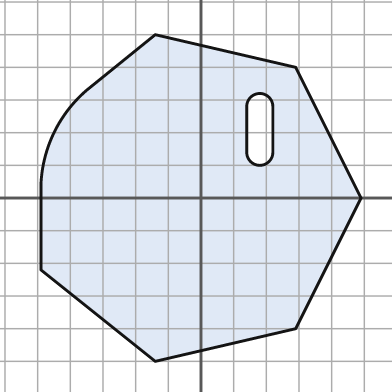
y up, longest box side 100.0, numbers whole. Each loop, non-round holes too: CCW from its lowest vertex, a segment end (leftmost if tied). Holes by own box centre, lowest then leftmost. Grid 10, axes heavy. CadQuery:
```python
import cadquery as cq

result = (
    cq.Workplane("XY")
    .moveTo(-14.0, -50.0)
    .lineTo(29.0, -40.0)
    .lineTo(49.0, 0.0)
    .lineTo(29.0, 40.0)
    .lineTo(-14.0, 50.0)
    .lineTo(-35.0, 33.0)
    .threePointArc((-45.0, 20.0), (-49.0, 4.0))
    .lineTo(-49.0, -22.0)
    .close()
    .moveTo(14.0, 14.0)
    .threePointArc((18.0, 10.0), (22.0, 14.0))
    .lineTo(22.0, 28.0)
    .threePointArc((18.0, 32.0), (14.0, 28.0))
    .close()
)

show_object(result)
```